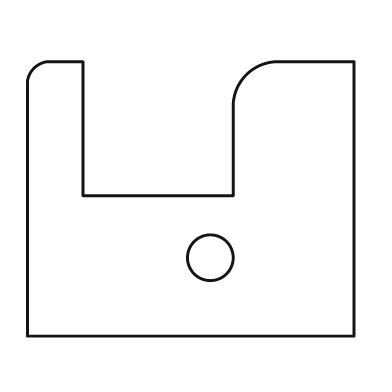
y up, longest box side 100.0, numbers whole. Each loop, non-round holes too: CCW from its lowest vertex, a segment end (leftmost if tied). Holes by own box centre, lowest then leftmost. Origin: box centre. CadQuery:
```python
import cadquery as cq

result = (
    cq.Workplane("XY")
    .moveTo(-50.0, -42.0)
    .lineTo(50.0, -42.0)
    .lineTo(50.0, 42.0)
    .lineTo(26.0, 42.0)
    .threePointArc((17.0, 38.0), (13.0, 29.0))
    .lineTo(13.0, 1.0)
    .lineTo(-33.0, 1.0)
    .lineTo(-33.0, 42.0)
    .lineTo(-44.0, 42.0)
    .threePointArc((-48.0, 40.0), (-50.0, 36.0))
    .close()
    .moveTo(6.0, -18.0)
    .circle(7.0)
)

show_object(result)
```